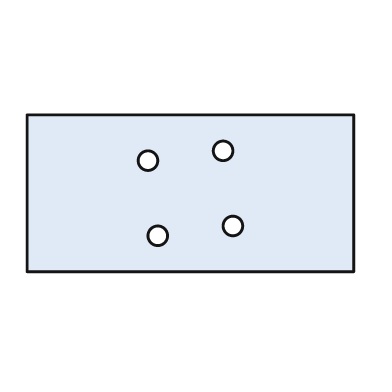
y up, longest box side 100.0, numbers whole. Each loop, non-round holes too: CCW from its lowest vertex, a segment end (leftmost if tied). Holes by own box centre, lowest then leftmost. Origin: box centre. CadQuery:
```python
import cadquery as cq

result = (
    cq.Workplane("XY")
    .moveTo(-50.0, -24.0)
    .lineTo(50.0, -24.0)
    .lineTo(50.0, 24.0)
    .lineTo(-50.0, 24.0)
    .close()
    .moveTo(-10.0, -13.0)
    .circle(3.0)
    .moveTo(13.0, -10.0)
    .circle(3.0)
    .moveTo(-13.0, 10.0)
    .circle(3.0)
    .moveTo(10.0, 13.0)
    .circle(3.0)
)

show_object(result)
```